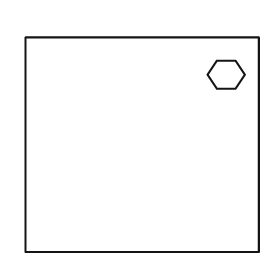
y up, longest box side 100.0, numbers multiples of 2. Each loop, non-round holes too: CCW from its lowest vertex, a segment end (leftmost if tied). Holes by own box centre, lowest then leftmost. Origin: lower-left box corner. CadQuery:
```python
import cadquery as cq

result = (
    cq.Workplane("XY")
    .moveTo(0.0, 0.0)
    .lineTo(100.0, 0.0)
    .lineTo(100.0, 92.0)
    .lineTo(0.0, 92.0)
    .close()
    .moveTo(82.0, 70.0)
    .lineTo(90.0, 70.0)
    .lineTo(94.0, 76.0)
    .lineTo(90.0, 82.0)
    .lineTo(82.0, 82.0)
    .lineTo(78.0, 76.0)
    .close()
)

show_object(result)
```